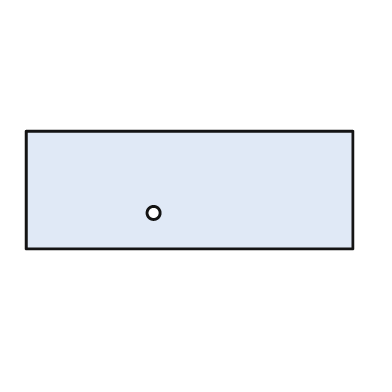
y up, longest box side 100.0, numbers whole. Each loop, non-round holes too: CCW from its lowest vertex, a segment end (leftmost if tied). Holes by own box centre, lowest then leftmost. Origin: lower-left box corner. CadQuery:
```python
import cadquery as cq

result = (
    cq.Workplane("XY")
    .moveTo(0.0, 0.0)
    .lineTo(100.0, 0.0)
    .lineTo(100.0, 36.0)
    .lineTo(0.0, 36.0)
    .close()
    .moveTo(39.0, 11.0)
    .circle(2.0)
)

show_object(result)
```